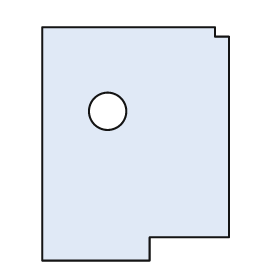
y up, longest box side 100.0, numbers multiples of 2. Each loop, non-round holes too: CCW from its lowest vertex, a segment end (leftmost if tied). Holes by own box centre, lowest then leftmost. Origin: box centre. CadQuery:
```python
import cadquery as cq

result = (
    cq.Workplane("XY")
    .moveTo(-40.0, -50.0)
    .lineTo(6.0, -50.0)
    .lineTo(6.0, -40.0)
    .lineTo(40.0, -40.0)
    .lineTo(40.0, 46.0)
    .lineTo(34.0, 46.0)
    .lineTo(34.0, 50.0)
    .lineTo(-40.0, 50.0)
    .close()
    .moveTo(-12.0, 14.0)
    .circle(8.0)
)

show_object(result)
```